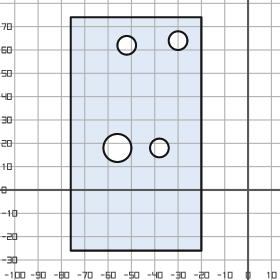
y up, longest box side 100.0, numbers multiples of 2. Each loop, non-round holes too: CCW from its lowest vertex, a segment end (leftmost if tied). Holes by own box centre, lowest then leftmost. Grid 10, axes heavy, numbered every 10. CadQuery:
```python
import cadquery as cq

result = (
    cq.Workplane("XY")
    .moveTo(-76.0, -26.0)
    .lineTo(-20.0, -26.0)
    .lineTo(-20.0, 74.0)
    .lineTo(-76.0, 74.0)
    .close()
    .moveTo(-56.0, 18.0)
    .circle(6.0)
    .moveTo(-38.0, 18.0)
    .circle(4.0)
    .moveTo(-52.0, 62.0)
    .circle(4.0)
    .moveTo(-30.0, 64.0)
    .circle(4.0)
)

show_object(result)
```